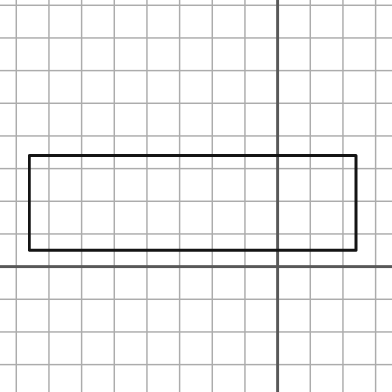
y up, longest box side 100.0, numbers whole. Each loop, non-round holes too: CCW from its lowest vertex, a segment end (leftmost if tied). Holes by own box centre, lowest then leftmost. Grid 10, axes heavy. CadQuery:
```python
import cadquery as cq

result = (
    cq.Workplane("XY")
    .moveTo(-76.0, 5.0)
    .lineTo(24.0, 5.0)
    .lineTo(24.0, 34.0)
    .lineTo(-76.0, 34.0)
    .close()
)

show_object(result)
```